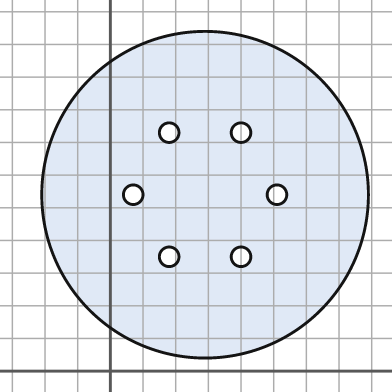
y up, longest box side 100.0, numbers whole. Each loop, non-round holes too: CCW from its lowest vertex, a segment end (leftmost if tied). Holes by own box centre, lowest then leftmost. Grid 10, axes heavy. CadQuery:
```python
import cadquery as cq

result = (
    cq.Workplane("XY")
    .moveTo(29.0, 54.0)
    .circle(50.0)
    .moveTo(18.0, 35.0)
    .circle(3.0)
    .moveTo(40.0, 35.0)
    .circle(3.0)
    .moveTo(7.0, 54.0)
    .circle(3.0)
    .moveTo(51.0, 54.0)
    .circle(3.0)
    .moveTo(18.0, 73.0)
    .circle(3.0)
    .moveTo(40.0, 73.0)
    .circle(3.0)
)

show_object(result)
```